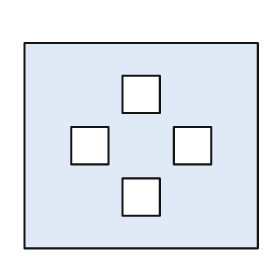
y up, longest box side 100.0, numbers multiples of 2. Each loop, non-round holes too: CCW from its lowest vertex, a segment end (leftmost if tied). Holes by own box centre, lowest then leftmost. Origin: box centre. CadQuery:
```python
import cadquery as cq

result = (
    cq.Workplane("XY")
    .moveTo(-50.0, -44.0)
    .lineTo(50.0, -44.0)
    .lineTo(50.0, 44.0)
    .lineTo(-50.0, 44.0)
    .close()
    .moveTo(-8.0, -30.0)
    .lineTo(8.0, -30.0)
    .lineTo(8.0, -14.0)
    .lineTo(-8.0, -14.0)
    .close()
    .moveTo(-30.0, -8.0)
    .lineTo(-14.0, -8.0)
    .lineTo(-14.0, 8.0)
    .lineTo(-30.0, 8.0)
    .close()
    .moveTo(14.0, -8.0)
    .lineTo(30.0, -8.0)
    .lineTo(30.0, 8.0)
    .lineTo(14.0, 8.0)
    .close()
    .moveTo(-8.0, 14.0)
    .lineTo(8.0, 14.0)
    .lineTo(8.0, 30.0)
    .lineTo(-8.0, 30.0)
    .close()
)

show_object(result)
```